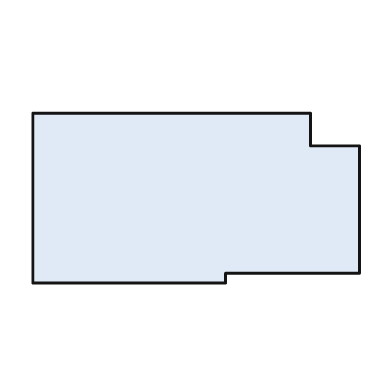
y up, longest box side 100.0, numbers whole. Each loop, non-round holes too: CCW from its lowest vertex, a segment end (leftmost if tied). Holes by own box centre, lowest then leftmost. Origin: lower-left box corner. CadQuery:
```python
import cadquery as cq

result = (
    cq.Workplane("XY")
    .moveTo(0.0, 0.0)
    .lineTo(59.0, 0.0)
    .lineTo(59.0, 3.0)
    .lineTo(100.0, 3.0)
    .lineTo(100.0, 42.0)
    .lineTo(85.0, 42.0)
    .lineTo(85.0, 52.0)
    .lineTo(0.0, 52.0)
    .close()
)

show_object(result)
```